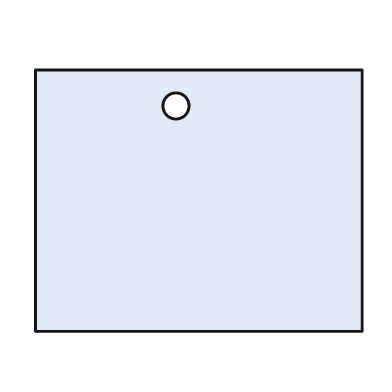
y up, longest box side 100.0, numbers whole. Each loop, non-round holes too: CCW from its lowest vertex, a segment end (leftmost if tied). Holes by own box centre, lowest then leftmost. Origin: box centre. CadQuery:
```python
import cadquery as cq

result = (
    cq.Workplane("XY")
    .moveTo(-50.0, -40.0)
    .lineTo(50.0, -40.0)
    .lineTo(50.0, 40.0)
    .lineTo(-50.0, 40.0)
    .close()
    .moveTo(-7.0, 29.0)
    .circle(4.0)
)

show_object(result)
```